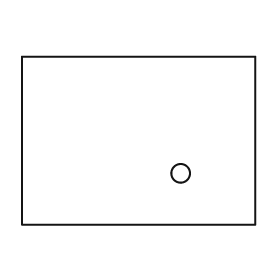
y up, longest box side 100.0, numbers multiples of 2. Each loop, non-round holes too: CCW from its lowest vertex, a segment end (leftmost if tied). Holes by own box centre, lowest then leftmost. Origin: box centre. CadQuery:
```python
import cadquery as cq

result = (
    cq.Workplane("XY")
    .moveTo(-50.0, -36.0)
    .lineTo(50.0, -36.0)
    .lineTo(50.0, 36.0)
    .lineTo(-50.0, 36.0)
    .close()
    .moveTo(18.0, -14.0)
    .circle(4.0)
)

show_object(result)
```